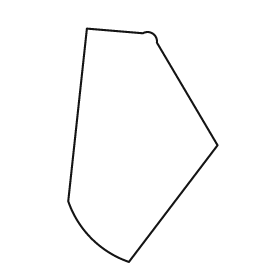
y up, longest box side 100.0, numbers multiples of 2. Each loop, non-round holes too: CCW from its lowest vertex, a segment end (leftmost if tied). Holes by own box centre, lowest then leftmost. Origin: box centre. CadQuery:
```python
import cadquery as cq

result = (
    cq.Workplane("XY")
    .moveTo(-6.0, -50.0)
    .lineTo(32.0, 0.0)
    .lineTo(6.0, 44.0)
    .threePointArc((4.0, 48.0), (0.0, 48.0))
    .lineTo(-24.0, 50.0)
    .lineTo(-32.0, -24.0)
    .threePointArc((-22.0, -40.0), (-6.0, -50.0))
    .close()
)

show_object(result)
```